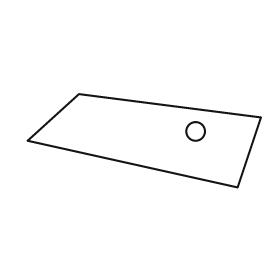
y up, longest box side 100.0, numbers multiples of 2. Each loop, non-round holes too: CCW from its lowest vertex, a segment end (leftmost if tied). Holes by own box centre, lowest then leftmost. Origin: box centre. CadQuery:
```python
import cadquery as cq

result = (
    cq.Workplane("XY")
    .moveTo(40.0, -20.0)
    .lineTo(50.0, 10.0)
    .lineTo(-28.0, 20.0)
    .lineTo(-50.0, 0.0)
    .close()
    .moveTo(22.0, 4.0)
    .circle(4.0)
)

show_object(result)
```